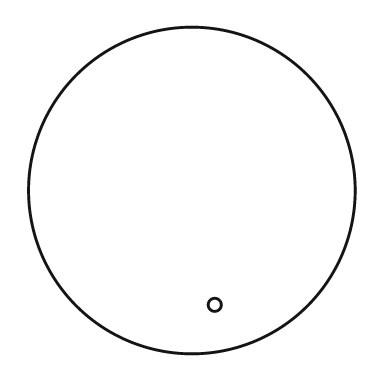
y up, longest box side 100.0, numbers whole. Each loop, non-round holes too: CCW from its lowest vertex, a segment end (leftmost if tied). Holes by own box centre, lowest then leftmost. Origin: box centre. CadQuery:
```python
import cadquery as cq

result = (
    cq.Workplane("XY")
    .moveTo(0.0, 0.0)
    .circle(50.0)
    .moveTo(7.0, -35.0)
    .circle(2.0)
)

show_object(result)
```